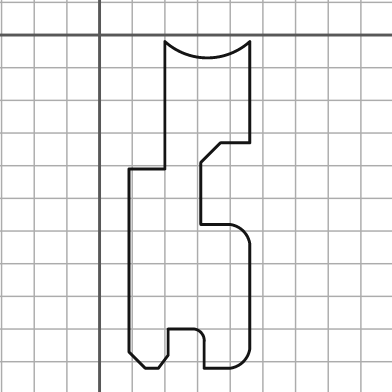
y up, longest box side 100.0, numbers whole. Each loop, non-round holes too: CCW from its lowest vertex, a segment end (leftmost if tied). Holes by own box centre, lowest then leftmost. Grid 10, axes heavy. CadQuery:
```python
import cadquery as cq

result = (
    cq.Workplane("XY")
    .moveTo(14.0, -102.0)
    .lineTo(18.0, -102.0)
    .lineTo(21.0, -98.0)
    .lineTo(21.0, -90.0)
    .lineTo(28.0, -90.0)
    .threePointArc((31.0, -91.0), (32.0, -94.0))
    .lineTo(32.0, -102.0)
    .lineTo(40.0, -102.0)
    .threePointArc((44.0, -100.0), (46.0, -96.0))
    .lineTo(46.0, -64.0)
    .threePointArc((44.0, -60.0), (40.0, -58.0))
    .lineTo(31.0, -58.0)
    .lineTo(31.0, -39.0)
    .lineTo(37.0, -33.0)
    .lineTo(46.0, -33.0)
    .lineTo(46.0, -2.0)
    .threePointArc((33.0, -7.0), (20.0, -2.0))
    .lineTo(20.0, -41.0)
    .lineTo(9.0, -41.0)
    .lineTo(9.0, -97.0)
    .close()
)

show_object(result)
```